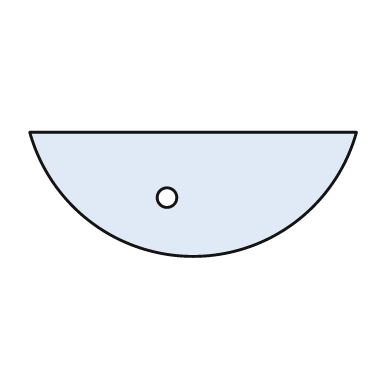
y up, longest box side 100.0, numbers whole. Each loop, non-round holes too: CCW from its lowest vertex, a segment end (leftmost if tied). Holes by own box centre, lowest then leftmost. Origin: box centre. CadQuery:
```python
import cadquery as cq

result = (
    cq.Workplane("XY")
    .moveTo(-50.0, 19.0)
    .threePointArc((0.0, -19.0), (50.0, 19.0))
    .close()
    .moveTo(-8.0, -1.0)
    .circle(3.0)
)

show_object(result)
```